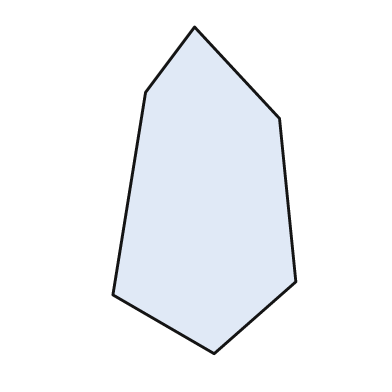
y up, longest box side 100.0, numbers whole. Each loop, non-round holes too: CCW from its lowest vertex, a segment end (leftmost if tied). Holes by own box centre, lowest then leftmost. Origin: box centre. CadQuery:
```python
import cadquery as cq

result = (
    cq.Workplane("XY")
    .moveTo(3.0, -50.0)
    .lineTo(28.0, -28.0)
    .lineTo(23.0, 22.0)
    .lineTo(-3.0, 50.0)
    .lineTo(-18.0, 30.0)
    .lineTo(-28.0, -32.0)
    .close()
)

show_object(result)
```